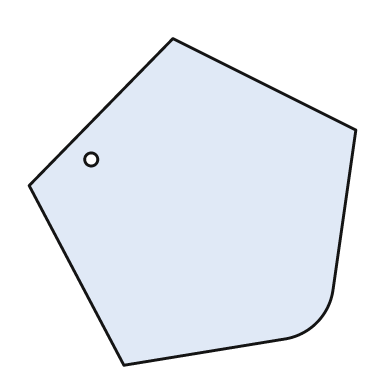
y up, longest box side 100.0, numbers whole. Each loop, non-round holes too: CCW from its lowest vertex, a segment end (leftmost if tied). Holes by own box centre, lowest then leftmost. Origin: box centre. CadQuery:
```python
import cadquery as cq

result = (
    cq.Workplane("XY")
    .moveTo(-21.0, -50.0)
    .lineTo(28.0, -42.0)
    .threePointArc((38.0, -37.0), (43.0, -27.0))
    .lineTo(50.0, 22.0)
    .lineTo(-6.0, 50.0)
    .lineTo(-50.0, 5.0)
    .close()
    .moveTo(-31.0, 13.0)
    .circle(2.0)
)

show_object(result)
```